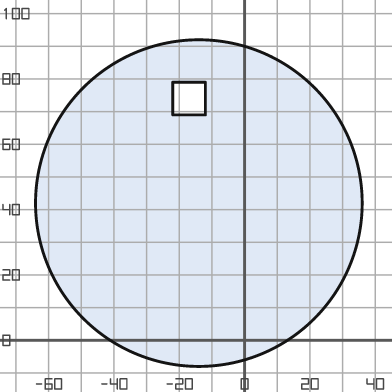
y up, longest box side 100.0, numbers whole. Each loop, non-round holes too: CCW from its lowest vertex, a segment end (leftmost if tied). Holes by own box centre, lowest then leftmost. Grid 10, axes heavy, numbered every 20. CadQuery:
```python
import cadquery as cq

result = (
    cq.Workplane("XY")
    .moveTo(-14.0, 42.0)
    .circle(50.0)
    .moveTo(-22.0, 69.0)
    .lineTo(-12.0, 69.0)
    .lineTo(-12.0, 79.0)
    .lineTo(-22.0, 79.0)
    .close()
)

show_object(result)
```